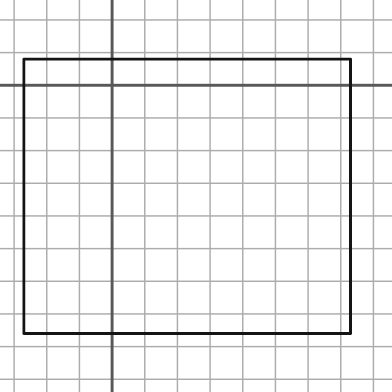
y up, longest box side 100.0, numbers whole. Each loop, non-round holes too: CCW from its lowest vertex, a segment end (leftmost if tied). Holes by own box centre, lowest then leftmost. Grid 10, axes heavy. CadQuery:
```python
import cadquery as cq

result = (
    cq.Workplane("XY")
    .moveTo(-27.0, -76.0)
    .lineTo(73.0, -76.0)
    .lineTo(73.0, 8.0)
    .lineTo(-27.0, 8.0)
    .close()
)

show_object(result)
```